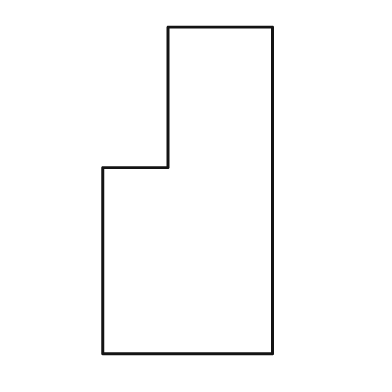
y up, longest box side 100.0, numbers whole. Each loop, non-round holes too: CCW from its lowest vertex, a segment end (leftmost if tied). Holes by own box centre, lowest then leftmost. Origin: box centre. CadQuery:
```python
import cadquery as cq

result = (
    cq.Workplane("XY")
    .moveTo(-26.0, -50.0)
    .lineTo(26.0, -50.0)
    .lineTo(26.0, 50.0)
    .lineTo(-6.0, 50.0)
    .lineTo(-6.0, 7.0)
    .lineTo(-26.0, 7.0)
    .close()
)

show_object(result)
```